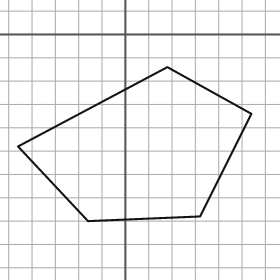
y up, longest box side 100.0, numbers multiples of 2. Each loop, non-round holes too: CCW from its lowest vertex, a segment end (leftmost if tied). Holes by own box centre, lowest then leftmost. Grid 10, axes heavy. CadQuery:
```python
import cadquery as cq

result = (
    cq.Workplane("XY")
    .moveTo(-16.0, -80.0)
    .lineTo(32.0, -78.0)
    .lineTo(54.0, -34.0)
    .lineTo(18.0, -14.0)
    .lineTo(-46.0, -48.0)
    .close()
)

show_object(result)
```